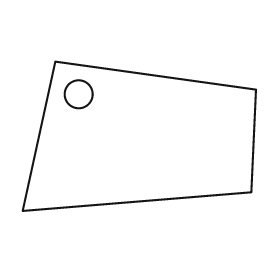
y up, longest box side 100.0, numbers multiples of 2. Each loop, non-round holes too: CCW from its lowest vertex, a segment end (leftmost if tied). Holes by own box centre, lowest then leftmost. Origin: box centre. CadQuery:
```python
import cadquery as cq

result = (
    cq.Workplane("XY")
    .moveTo(-50.0, -32.0)
    .lineTo(48.0, -24.0)
    .lineTo(50.0, 20.0)
    .lineTo(-36.0, 32.0)
    .close()
    .moveTo(-26.0, 18.0)
    .circle(6.0)
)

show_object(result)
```